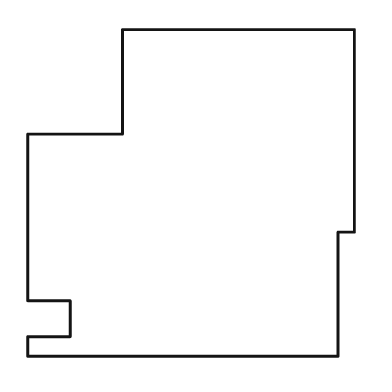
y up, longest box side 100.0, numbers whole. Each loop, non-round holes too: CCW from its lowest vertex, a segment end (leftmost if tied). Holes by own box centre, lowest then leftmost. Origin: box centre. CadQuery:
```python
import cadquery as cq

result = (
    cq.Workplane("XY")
    .moveTo(-50.0, -50.0)
    .lineTo(45.0, -50.0)
    .lineTo(45.0, -12.0)
    .lineTo(50.0, -12.0)
    .lineTo(50.0, 50.0)
    .lineTo(-21.0, 50.0)
    .lineTo(-21.0, 18.0)
    .lineTo(-50.0, 18.0)
    .lineTo(-50.0, -33.0)
    .lineTo(-37.0, -33.0)
    .lineTo(-37.0, -44.0)
    .lineTo(-50.0, -44.0)
    .close()
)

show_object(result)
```